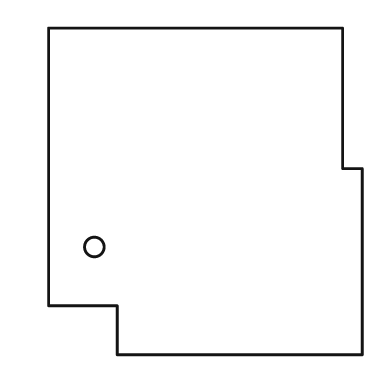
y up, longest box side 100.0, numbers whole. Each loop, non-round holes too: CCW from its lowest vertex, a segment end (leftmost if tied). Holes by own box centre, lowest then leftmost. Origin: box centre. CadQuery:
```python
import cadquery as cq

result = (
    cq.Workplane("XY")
    .moveTo(-27.0, -50.0)
    .lineTo(48.0, -50.0)
    .lineTo(48.0, 7.0)
    .lineTo(42.0, 7.0)
    .lineTo(42.0, 50.0)
    .lineTo(-48.0, 50.0)
    .lineTo(-48.0, -35.0)
    .lineTo(-27.0, -35.0)
    .close()
    .moveTo(-34.0, -17.0)
    .circle(3.0)
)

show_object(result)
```